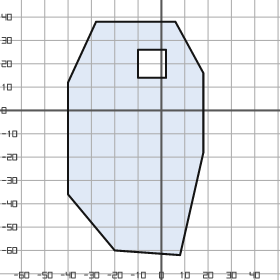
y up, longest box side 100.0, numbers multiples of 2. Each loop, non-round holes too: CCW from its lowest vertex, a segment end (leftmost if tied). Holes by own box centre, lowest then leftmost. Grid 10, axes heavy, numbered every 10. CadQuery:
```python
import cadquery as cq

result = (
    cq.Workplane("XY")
    .moveTo(8.0, -62.0)
    .lineTo(18.0, -18.0)
    .lineTo(18.0, 16.0)
    .lineTo(6.0, 38.0)
    .lineTo(-28.0, 38.0)
    .lineTo(-40.0, 12.0)
    .lineTo(-40.0, -36.0)
    .lineTo(-20.0, -60.0)
    .close()
    .moveTo(-10.0, 14.0)
    .lineTo(2.0, 14.0)
    .lineTo(2.0, 26.0)
    .lineTo(-10.0, 26.0)
    .close()
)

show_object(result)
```